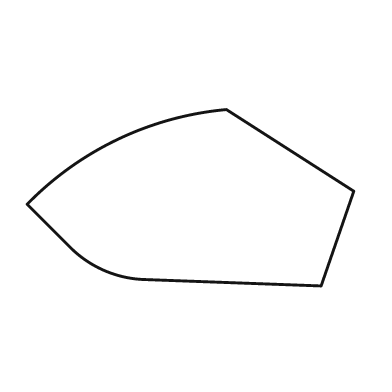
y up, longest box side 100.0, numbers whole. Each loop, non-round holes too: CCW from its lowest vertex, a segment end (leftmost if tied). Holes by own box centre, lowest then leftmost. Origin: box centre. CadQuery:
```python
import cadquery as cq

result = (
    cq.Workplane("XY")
    .moveTo(40.0, -27.0)
    .lineTo(50.0, 2.0)
    .lineTo(11.0, 27.0)
    .threePointArc((-22.0, 18.0), (-50.0, -2.0))
    .lineTo(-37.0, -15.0)
    .threePointArc((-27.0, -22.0), (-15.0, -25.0))
    .close()
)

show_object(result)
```